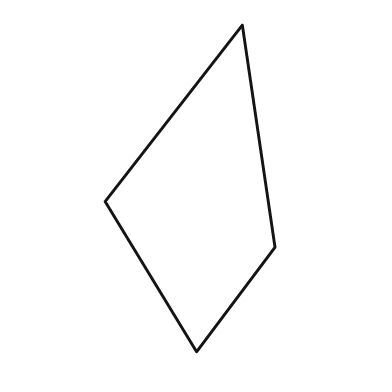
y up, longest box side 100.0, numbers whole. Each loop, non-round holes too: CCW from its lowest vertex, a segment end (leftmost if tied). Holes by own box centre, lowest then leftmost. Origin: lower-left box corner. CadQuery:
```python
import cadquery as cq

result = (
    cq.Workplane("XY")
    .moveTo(28.0, 0.0)
    .lineTo(52.0, 32.0)
    .lineTo(42.0, 100.0)
    .lineTo(0.0, 46.0)
    .close()
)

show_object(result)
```